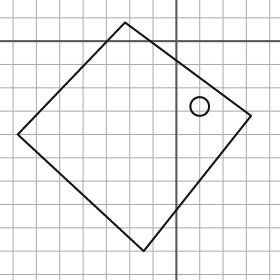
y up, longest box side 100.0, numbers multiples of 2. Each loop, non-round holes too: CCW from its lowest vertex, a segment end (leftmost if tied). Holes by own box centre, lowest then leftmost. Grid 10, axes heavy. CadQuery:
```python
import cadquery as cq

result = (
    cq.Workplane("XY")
    .moveTo(-14.0, -90.0)
    .lineTo(32.0, -32.0)
    .lineTo(-22.0, 8.0)
    .lineTo(-68.0, -40.0)
    .close()
    .moveTo(10.0, -28.0)
    .circle(4.0)
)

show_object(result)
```